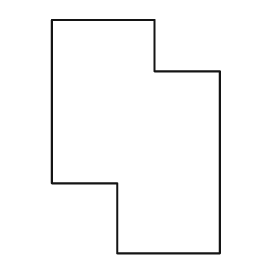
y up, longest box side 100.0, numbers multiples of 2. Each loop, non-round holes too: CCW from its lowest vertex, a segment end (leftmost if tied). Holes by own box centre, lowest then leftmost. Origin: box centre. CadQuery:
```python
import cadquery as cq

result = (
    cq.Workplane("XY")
    .moveTo(-8.0, -50.0)
    .lineTo(36.0, -50.0)
    .lineTo(36.0, 28.0)
    .lineTo(8.0, 28.0)
    .lineTo(8.0, 50.0)
    .lineTo(-36.0, 50.0)
    .lineTo(-36.0, -20.0)
    .lineTo(-8.0, -20.0)
    .close()
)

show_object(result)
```